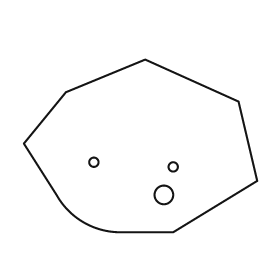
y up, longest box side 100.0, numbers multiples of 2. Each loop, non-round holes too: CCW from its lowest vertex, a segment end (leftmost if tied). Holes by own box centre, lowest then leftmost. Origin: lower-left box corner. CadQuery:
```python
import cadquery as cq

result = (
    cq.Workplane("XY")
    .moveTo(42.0, 0.0)
    .lineTo(64.0, 0.0)
    .lineTo(100.0, 22.0)
    .lineTo(92.0, 56.0)
    .lineTo(52.0, 74.0)
    .lineTo(18.0, 60.0)
    .lineTo(0.0, 38.0)
    .lineTo(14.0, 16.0)
    .threePointArc((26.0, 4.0), (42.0, 0.0))
    .close()
    .moveTo(60.0, 16.0)
    .circle(4.0)
    .moveTo(64.0, 28.0)
    .circle(2.0)
    .moveTo(30.0, 30.0)
    .circle(2.0)
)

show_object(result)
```